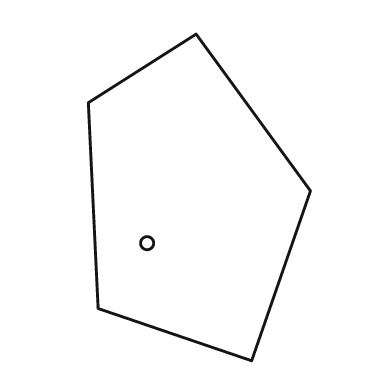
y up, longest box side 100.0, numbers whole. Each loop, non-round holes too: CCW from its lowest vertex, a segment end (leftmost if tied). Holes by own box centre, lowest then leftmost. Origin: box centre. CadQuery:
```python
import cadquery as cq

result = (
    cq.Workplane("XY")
    .moveTo(16.0, -50.0)
    .lineTo(34.0, 2.0)
    .lineTo(-1.0, 50.0)
    .lineTo(-34.0, 29.0)
    .lineTo(-31.0, -34.0)
    .close()
    .moveTo(-16.0, -14.0)
    .circle(2.0)
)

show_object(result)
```